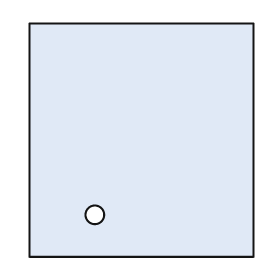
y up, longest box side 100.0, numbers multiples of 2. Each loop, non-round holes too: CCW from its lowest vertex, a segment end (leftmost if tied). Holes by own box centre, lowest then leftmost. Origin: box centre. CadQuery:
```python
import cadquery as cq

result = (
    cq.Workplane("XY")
    .moveTo(-48.0, -50.0)
    .lineTo(48.0, -50.0)
    .lineTo(48.0, 50.0)
    .lineTo(-48.0, 50.0)
    .close()
    .moveTo(-20.0, -32.0)
    .circle(4.0)
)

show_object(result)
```